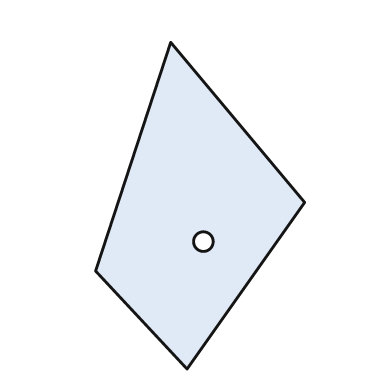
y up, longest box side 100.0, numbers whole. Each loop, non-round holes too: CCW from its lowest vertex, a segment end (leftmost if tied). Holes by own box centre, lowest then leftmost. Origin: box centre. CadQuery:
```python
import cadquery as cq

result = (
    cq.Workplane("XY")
    .moveTo(-4.0, -50.0)
    .lineTo(32.0, 1.0)
    .lineTo(-9.0, 50.0)
    .lineTo(-32.0, -20.0)
    .close()
    .moveTo(1.0, -11.0)
    .circle(3.0)
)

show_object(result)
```